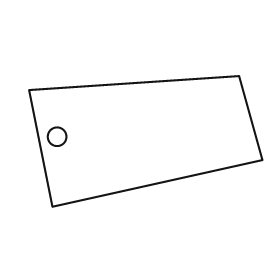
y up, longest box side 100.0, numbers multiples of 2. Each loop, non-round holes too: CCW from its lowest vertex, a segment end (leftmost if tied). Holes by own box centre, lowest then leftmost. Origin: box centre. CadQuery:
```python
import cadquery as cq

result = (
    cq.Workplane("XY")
    .moveTo(-40.0, -28.0)
    .lineTo(50.0, -8.0)
    .lineTo(40.0, 28.0)
    .lineTo(-50.0, 22.0)
    .close()
    .moveTo(-38.0, 2.0)
    .circle(4.0)
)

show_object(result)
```